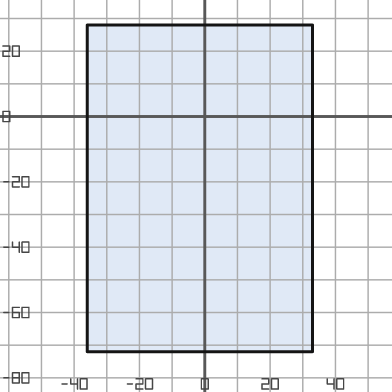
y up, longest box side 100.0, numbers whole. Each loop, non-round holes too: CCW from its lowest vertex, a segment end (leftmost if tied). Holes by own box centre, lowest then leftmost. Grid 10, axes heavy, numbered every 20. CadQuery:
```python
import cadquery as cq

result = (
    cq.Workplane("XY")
    .moveTo(-36.0, -72.0)
    .lineTo(33.0, -72.0)
    .lineTo(33.0, 28.0)
    .lineTo(-36.0, 28.0)
    .close()
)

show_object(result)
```